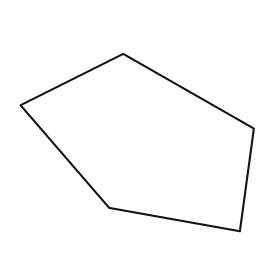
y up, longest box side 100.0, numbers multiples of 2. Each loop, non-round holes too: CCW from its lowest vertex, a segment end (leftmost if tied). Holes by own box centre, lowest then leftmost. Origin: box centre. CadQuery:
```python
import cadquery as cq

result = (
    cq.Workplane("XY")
    .moveTo(44.0, -38.0)
    .lineTo(50.0, 6.0)
    .lineTo(-6.0, 38.0)
    .lineTo(-50.0, 16.0)
    .lineTo(-12.0, -28.0)
    .close()
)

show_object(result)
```